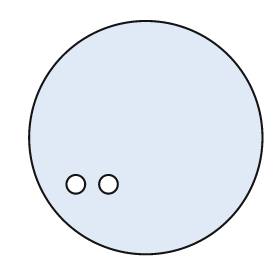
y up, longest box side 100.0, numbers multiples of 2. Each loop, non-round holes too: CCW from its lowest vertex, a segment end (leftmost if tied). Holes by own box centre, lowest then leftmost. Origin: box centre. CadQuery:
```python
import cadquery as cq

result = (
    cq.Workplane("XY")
    .moveTo(0.0, 0.0)
    .circle(50.0)
    .moveTo(-30.0, -20.0)
    .circle(4.0)
    .moveTo(-16.0, -20.0)
    .circle(4.0)
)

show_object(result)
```